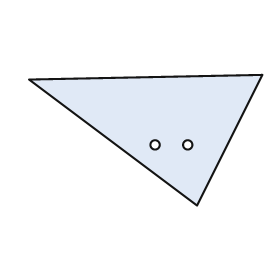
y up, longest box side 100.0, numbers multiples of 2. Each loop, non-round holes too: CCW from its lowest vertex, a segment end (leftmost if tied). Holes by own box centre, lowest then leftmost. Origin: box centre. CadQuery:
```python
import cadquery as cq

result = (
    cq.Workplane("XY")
    .moveTo(22.0, -28.0)
    .lineTo(50.0, 28.0)
    .lineTo(-50.0, 26.0)
    .close()
    .moveTo(4.0, -2.0)
    .circle(2.0)
    .moveTo(18.0, -2.0)
    .circle(2.0)
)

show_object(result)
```